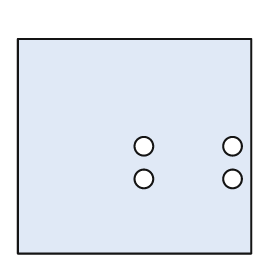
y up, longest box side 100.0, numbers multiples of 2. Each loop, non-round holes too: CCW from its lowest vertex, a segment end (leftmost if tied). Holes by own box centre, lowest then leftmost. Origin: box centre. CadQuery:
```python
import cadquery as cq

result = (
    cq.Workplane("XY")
    .moveTo(-50.0, -46.0)
    .lineTo(50.0, -46.0)
    .lineTo(50.0, 46.0)
    .lineTo(-50.0, 46.0)
    .close()
    .moveTo(4.0, -14.0)
    .circle(4.0)
    .moveTo(42.0, -14.0)
    .circle(4.0)
    .moveTo(4.0, 0.0)
    .circle(4.0)
    .moveTo(42.0, 0.0)
    .circle(4.0)
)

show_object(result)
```